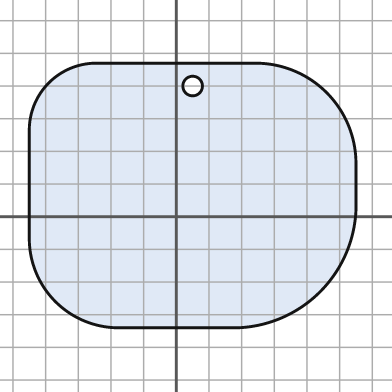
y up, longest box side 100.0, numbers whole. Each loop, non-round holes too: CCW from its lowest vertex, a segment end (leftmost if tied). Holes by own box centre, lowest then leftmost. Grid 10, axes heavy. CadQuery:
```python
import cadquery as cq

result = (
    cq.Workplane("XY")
    .moveTo(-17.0, -34.0)
    .lineTo(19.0, -34.0)
    .threePointArc((44.0, -23.0), (55.0, 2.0))
    .lineTo(55.0, 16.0)
    .threePointArc((46.0, 38.0), (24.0, 47.0))
    .lineTo(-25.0, 47.0)
    .threePointArc((-39.0, 41.0), (-45.0, 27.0))
    .lineTo(-45.0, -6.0)
    .threePointArc((-37.0, -26.0), (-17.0, -34.0))
    .close()
    .moveTo(5.0, 40.0)
    .circle(3.0)
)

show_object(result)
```